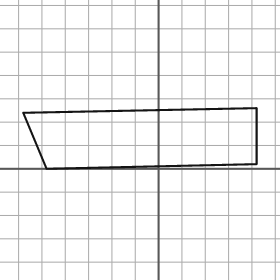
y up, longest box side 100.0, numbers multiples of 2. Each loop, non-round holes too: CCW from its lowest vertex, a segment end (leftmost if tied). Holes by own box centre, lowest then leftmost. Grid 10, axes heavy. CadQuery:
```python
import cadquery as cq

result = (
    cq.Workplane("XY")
    .moveTo(-48.0, 0.0)
    .lineTo(42.0, 2.0)
    .lineTo(42.0, 26.0)
    .lineTo(-58.0, 24.0)
    .close()
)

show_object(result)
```